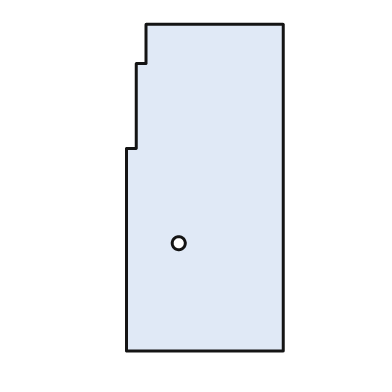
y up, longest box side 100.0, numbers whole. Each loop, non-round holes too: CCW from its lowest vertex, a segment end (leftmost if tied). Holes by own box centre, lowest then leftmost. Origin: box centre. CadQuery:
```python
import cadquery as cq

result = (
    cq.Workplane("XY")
    .moveTo(-24.0, -50.0)
    .lineTo(24.0, -50.0)
    .lineTo(24.0, 50.0)
    .lineTo(-18.0, 50.0)
    .lineTo(-18.0, 38.0)
    .lineTo(-21.0, 38.0)
    .lineTo(-21.0, 12.0)
    .lineTo(-24.0, 12.0)
    .close()
    .moveTo(-8.0, -17.0)
    .circle(2.0)
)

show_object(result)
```